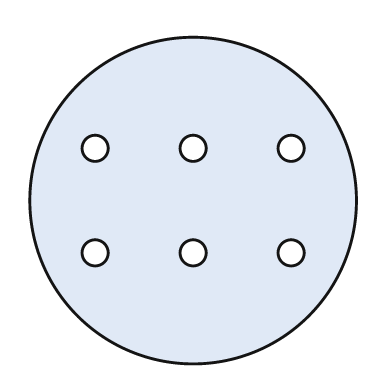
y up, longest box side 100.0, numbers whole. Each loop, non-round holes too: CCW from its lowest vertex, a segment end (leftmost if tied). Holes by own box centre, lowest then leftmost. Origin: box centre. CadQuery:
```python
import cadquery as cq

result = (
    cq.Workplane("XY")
    .moveTo(0.0, 0.0)
    .circle(50.0)
    .moveTo(-30.0, -16.0)
    .circle(4.0)
    .moveTo(0.0, -16.0)
    .circle(4.0)
    .moveTo(30.0, -16.0)
    .circle(4.0)
    .moveTo(-30.0, 16.0)
    .circle(4.0)
    .moveTo(0.0, 16.0)
    .circle(4.0)
    .moveTo(30.0, 16.0)
    .circle(4.0)
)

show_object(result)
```